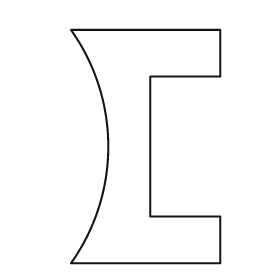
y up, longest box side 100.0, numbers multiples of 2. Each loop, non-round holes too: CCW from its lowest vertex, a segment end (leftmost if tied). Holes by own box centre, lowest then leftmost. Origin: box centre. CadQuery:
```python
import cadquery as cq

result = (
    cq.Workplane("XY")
    .moveTo(-32.0, -50.0)
    .lineTo(32.0, -50.0)
    .lineTo(32.0, -30.0)
    .lineTo(2.0, -30.0)
    .lineTo(2.0, 30.0)
    .lineTo(32.0, 30.0)
    .lineTo(32.0, 50.0)
    .lineTo(-32.0, 50.0)
    .threePointArc((-16.0, 0.0), (-32.0, -50.0))
    .close()
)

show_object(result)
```